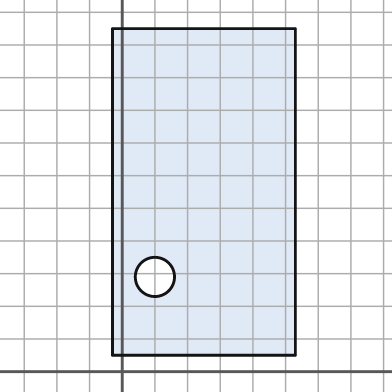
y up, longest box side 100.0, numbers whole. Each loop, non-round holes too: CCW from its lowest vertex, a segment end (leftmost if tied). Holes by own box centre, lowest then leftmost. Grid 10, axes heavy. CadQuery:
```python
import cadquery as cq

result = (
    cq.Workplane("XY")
    .moveTo(-3.0, 5.0)
    .lineTo(53.0, 5.0)
    .lineTo(53.0, 105.0)
    .lineTo(-3.0, 105.0)
    .close()
    .moveTo(10.0, 29.0)
    .circle(6.0)
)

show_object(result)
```